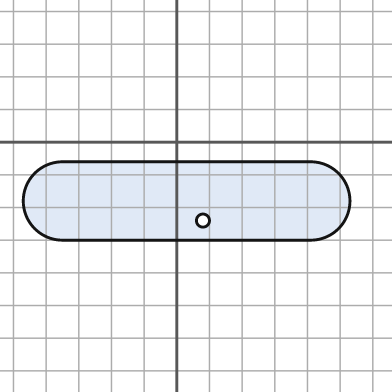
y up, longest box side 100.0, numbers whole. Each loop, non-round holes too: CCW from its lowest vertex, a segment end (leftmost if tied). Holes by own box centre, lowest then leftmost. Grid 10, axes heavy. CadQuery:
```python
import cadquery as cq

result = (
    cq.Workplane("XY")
    .moveTo(-35.0, -30.0)
    .lineTo(41.0, -30.0)
    .threePointArc((53.0, -18.0), (41.0, -6.0))
    .lineTo(-35.0, -6.0)
    .threePointArc((-47.0, -18.0), (-35.0, -30.0))
    .close()
    .moveTo(8.0, -24.0)
    .circle(2.0)
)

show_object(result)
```